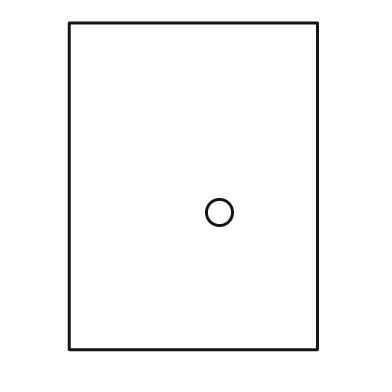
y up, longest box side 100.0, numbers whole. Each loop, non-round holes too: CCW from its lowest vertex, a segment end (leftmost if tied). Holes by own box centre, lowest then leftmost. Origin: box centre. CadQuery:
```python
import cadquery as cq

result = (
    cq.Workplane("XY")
    .moveTo(-38.0, -50.0)
    .lineTo(38.0, -50.0)
    .lineTo(38.0, 50.0)
    .lineTo(-38.0, 50.0)
    .close()
    .moveTo(8.0, -8.0)
    .circle(4.0)
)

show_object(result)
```